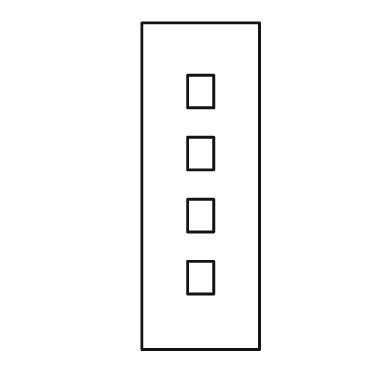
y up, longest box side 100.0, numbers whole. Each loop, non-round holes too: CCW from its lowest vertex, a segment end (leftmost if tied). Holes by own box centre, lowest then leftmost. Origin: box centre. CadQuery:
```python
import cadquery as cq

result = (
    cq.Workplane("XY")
    .moveTo(-18.0, -50.0)
    .lineTo(18.0, -50.0)
    .lineTo(18.0, 50.0)
    .lineTo(-18.0, 50.0)
    .close()
    .moveTo(-4.0, -33.0)
    .lineTo(4.0, -33.0)
    .lineTo(4.0, -23.0)
    .lineTo(-4.0, -23.0)
    .close()
    .moveTo(-4.0, -14.0)
    .lineTo(4.0, -14.0)
    .lineTo(4.0, -4.0)
    .lineTo(-4.0, -4.0)
    .close()
    .moveTo(-4.0, 5.0)
    .lineTo(4.0, 5.0)
    .lineTo(4.0, 15.0)
    .lineTo(-4.0, 15.0)
    .close()
    .moveTo(-4.0, 24.0)
    .lineTo(4.0, 24.0)
    .lineTo(4.0, 34.0)
    .lineTo(-4.0, 34.0)
    .close()
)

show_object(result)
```